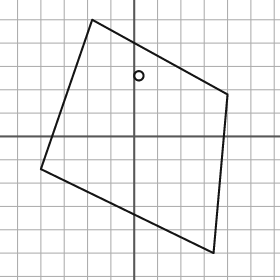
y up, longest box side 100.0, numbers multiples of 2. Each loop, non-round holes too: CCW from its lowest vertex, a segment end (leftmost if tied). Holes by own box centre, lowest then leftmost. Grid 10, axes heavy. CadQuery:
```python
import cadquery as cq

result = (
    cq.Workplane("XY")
    .moveTo(34.0, -50.0)
    .lineTo(40.0, 18.0)
    .lineTo(-18.0, 50.0)
    .lineTo(-40.0, -14.0)
    .close()
    .moveTo(2.0, 26.0)
    .circle(2.0)
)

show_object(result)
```